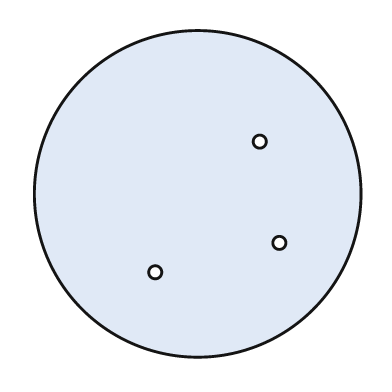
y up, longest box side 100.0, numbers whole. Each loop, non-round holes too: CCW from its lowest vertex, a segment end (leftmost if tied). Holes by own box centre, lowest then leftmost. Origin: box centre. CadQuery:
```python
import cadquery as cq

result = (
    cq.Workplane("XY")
    .moveTo(0.0, 0.0)
    .circle(50.0)
    .moveTo(-13.0, -24.0)
    .circle(2.0)
    .moveTo(25.0, -15.0)
    .circle(2.0)
    .moveTo(19.0, 16.0)
    .circle(2.0)
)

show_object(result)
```